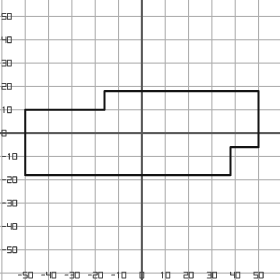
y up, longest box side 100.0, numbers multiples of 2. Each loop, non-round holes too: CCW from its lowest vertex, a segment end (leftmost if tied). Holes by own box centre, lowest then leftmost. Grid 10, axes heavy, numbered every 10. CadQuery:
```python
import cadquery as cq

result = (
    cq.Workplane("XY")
    .moveTo(-50.0, -18.0)
    .lineTo(38.0, -18.0)
    .lineTo(38.0, -6.0)
    .lineTo(50.0, -6.0)
    .lineTo(50.0, 18.0)
    .lineTo(-16.0, 18.0)
    .lineTo(-16.0, 10.0)
    .lineTo(-50.0, 10.0)
    .close()
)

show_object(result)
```